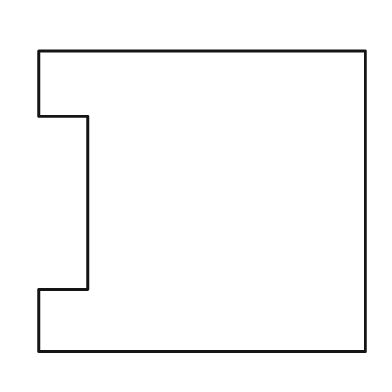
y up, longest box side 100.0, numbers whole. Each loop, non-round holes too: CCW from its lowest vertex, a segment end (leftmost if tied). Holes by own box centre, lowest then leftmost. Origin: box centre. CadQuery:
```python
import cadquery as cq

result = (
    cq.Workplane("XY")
    .moveTo(-50.0, -46.0)
    .lineTo(50.0, -46.0)
    .lineTo(50.0, 46.0)
    .lineTo(-50.0, 46.0)
    .lineTo(-50.0, 26.0)
    .lineTo(-35.0, 26.0)
    .lineTo(-35.0, -27.0)
    .lineTo(-50.0, -27.0)
    .close()
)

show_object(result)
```